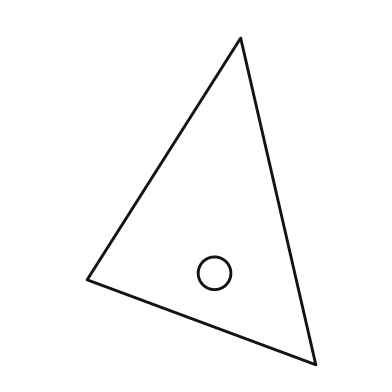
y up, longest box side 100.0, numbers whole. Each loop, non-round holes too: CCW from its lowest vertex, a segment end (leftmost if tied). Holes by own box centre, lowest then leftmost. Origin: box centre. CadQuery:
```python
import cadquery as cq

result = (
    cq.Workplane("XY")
    .moveTo(35.0, -50.0)
    .lineTo(12.0, 50.0)
    .lineTo(-35.0, -24.0)
    .close()
    .moveTo(4.0, -22.0)
    .circle(5.0)
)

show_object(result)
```